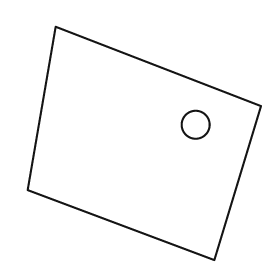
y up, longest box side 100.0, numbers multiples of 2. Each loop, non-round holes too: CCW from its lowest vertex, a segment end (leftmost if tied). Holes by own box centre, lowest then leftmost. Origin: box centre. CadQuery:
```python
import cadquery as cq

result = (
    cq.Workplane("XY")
    .moveTo(30.0, -50.0)
    .lineTo(50.0, 16.0)
    .lineTo(-38.0, 50.0)
    .lineTo(-50.0, -20.0)
    .close()
    .moveTo(22.0, 8.0)
    .circle(6.0)
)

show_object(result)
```